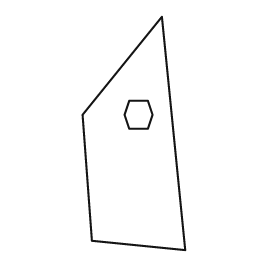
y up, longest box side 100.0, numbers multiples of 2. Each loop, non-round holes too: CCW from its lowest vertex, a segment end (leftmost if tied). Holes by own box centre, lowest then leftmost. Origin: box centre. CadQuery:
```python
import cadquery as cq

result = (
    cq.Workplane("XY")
    .moveTo(22.0, -50.0)
    .lineTo(12.0, 50.0)
    .lineTo(-22.0, 8.0)
    .lineTo(-18.0, -46.0)
    .close()
    .moveTo(-2.0, 2.0)
    .lineTo(6.0, 2.0)
    .lineTo(8.0, 8.0)
    .lineTo(6.0, 14.0)
    .lineTo(-2.0, 14.0)
    .lineTo(-4.0, 8.0)
    .close()
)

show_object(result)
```